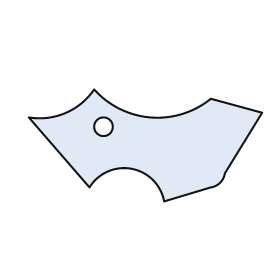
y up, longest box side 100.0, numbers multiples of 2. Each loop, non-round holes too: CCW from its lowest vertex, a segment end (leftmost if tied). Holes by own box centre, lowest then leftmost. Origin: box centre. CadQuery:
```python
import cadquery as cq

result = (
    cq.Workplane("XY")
    .moveTo(8.0, -24.0)
    .lineTo(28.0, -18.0)
    .threePointArc((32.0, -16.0), (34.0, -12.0))
    .lineTo(50.0, 14.0)
    .lineTo(28.0, 20.0)
    .threePointArc((2.0, 12.0), (-22.0, 24.0))
    .threePointArc((-34.0, 14.0), (-50.0, 12.0))
    .lineTo(-24.0, -18.0)
    .threePointArc((-6.0, -10.0), (8.0, -24.0))
    .close()
    .moveTo(-18.0, 8.0)
    .circle(4.0)
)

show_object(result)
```